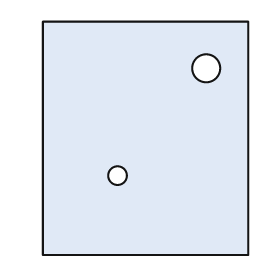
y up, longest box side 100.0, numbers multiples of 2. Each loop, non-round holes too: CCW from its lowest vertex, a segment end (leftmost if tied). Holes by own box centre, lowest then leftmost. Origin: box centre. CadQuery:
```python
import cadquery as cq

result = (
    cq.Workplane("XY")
    .moveTo(-44.0, -50.0)
    .lineTo(44.0, -50.0)
    .lineTo(44.0, 50.0)
    .lineTo(-44.0, 50.0)
    .close()
    .moveTo(-12.0, -16.0)
    .circle(4.0)
    .moveTo(26.0, 30.0)
    .circle(6.0)
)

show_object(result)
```